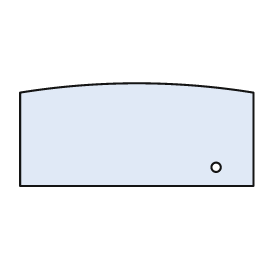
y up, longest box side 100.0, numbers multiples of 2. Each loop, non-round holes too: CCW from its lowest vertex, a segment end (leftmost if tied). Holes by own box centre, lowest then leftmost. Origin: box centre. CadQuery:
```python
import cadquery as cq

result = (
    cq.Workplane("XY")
    .moveTo(-50.0, -22.0)
    .lineTo(50.0, -22.0)
    .lineTo(50.0, 18.0)
    .threePointArc((0.0, 22.0), (-50.0, 18.0))
    .close()
    .moveTo(34.0, -14.0)
    .circle(2.0)
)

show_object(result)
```